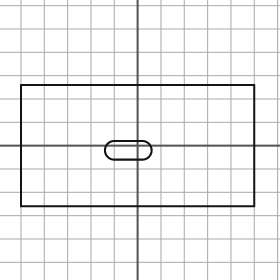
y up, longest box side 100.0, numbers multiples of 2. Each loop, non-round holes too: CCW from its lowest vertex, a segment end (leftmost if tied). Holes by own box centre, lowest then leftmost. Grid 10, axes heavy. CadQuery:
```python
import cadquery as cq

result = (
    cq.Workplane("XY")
    .moveTo(-50.0, -26.0)
    .lineTo(50.0, -26.0)
    .lineTo(50.0, 26.0)
    .lineTo(-50.0, 26.0)
    .close()
    .moveTo(-10.0, -6.0)
    .lineTo(2.0, -6.0)
    .threePointArc((6.0, -2.0), (2.0, 2.0))
    .lineTo(-10.0, 2.0)
    .threePointArc((-14.0, -2.0), (-10.0, -6.0))
    .close()
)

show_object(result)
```